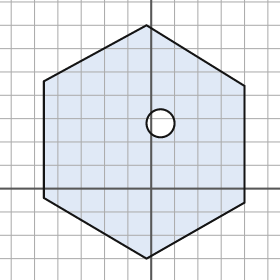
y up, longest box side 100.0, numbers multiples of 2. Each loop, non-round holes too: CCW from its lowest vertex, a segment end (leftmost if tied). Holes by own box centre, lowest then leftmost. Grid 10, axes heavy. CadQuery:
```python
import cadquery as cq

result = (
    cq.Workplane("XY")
    .moveTo(-2.0, -30.0)
    .lineTo(40.0, -6.0)
    .lineTo(40.0, 44.0)
    .lineTo(-2.0, 70.0)
    .lineTo(-46.0, 46.0)
    .lineTo(-46.0, -4.0)
    .close()
    .moveTo(4.0, 28.0)
    .circle(6.0)
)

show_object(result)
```